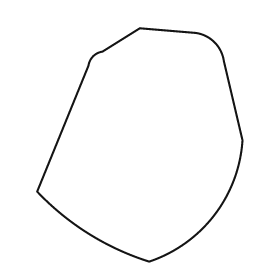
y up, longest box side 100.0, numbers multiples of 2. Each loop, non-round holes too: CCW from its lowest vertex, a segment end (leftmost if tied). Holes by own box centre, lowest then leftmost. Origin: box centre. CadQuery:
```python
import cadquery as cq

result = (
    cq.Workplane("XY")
    .moveTo(4.0, -50.0)
    .threePointArc((32.0, -30.0), (44.0, 2.0))
    .lineTo(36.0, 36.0)
    .threePointArc((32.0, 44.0), (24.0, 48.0))
    .lineTo(0.0, 50.0)
    .lineTo(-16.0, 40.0)
    .threePointArc((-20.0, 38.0), (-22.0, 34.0))
    .lineTo(-44.0, -20.0)
    .threePointArc((-22.0, -38.0), (4.0, -50.0))
    .close()
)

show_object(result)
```